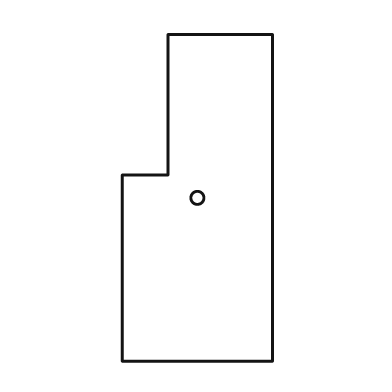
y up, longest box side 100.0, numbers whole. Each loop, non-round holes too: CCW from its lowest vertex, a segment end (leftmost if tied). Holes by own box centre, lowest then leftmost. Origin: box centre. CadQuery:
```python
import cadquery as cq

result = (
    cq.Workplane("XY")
    .moveTo(-23.0, -50.0)
    .lineTo(23.0, -50.0)
    .lineTo(23.0, 50.0)
    .lineTo(-9.0, 50.0)
    .lineTo(-9.0, 7.0)
    .lineTo(-23.0, 7.0)
    .close()
    .moveTo(0.0, 0.0)
    .circle(2.0)
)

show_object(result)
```